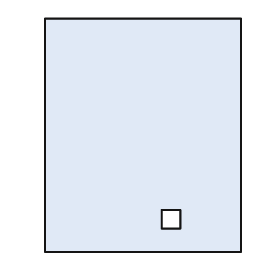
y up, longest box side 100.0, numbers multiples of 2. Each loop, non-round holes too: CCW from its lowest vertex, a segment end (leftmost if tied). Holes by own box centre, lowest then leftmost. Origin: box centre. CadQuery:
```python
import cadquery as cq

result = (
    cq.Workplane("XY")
    .moveTo(-42.0, -50.0)
    .lineTo(42.0, -50.0)
    .lineTo(42.0, 50.0)
    .lineTo(-42.0, 50.0)
    .close()
    .moveTo(8.0, -40.0)
    .lineTo(16.0, -40.0)
    .lineTo(16.0, -32.0)
    .lineTo(8.0, -32.0)
    .close()
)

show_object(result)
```